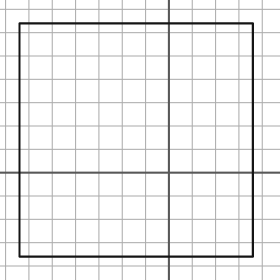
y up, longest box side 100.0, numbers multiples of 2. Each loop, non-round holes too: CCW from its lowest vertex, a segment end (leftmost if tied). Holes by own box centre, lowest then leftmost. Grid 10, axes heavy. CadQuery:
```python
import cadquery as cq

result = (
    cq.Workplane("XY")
    .moveTo(-64.0, -36.0)
    .lineTo(36.0, -36.0)
    .lineTo(36.0, 64.0)
    .lineTo(-64.0, 64.0)
    .close()
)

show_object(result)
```